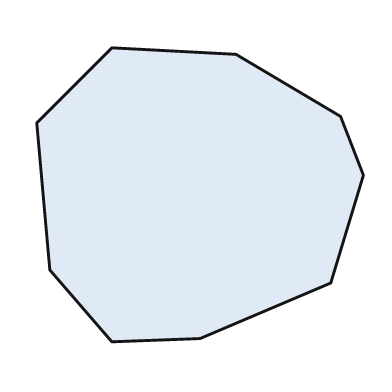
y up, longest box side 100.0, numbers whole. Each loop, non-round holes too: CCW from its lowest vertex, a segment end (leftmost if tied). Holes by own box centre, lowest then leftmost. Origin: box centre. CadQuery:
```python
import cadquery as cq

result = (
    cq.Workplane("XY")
    .moveTo(-27.0, -45.0)
    .lineTo(0.0, -44.0)
    .lineTo(40.0, -27.0)
    .lineTo(50.0, 6.0)
    .lineTo(43.0, 24.0)
    .lineTo(11.0, 43.0)
    .lineTo(-27.0, 45.0)
    .lineTo(-50.0, 22.0)
    .lineTo(-46.0, -23.0)
    .close()
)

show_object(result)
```